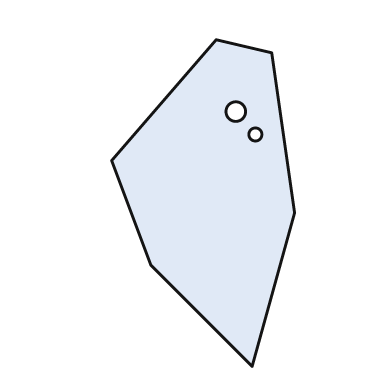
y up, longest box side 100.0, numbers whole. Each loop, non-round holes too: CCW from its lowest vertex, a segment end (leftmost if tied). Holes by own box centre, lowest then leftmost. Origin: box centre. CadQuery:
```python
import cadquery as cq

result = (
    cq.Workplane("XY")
    .moveTo(15.0, -50.0)
    .lineTo(28.0, -3.0)
    .lineTo(21.0, 46.0)
    .lineTo(4.0, 50.0)
    .lineTo(-28.0, 13.0)
    .lineTo(-16.0, -19.0)
    .close()
    .moveTo(16.0, 21.0)
    .circle(2.0)
    .moveTo(10.0, 28.0)
    .circle(3.0)
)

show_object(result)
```